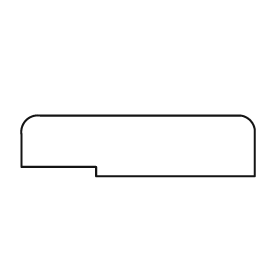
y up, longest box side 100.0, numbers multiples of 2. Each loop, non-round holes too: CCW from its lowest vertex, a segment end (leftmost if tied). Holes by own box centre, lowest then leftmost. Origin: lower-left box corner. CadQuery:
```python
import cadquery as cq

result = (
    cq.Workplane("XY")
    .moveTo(32.0, 0.0)
    .lineTo(100.0, 0.0)
    .lineTo(100.0, 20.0)
    .threePointArc((98.0, 24.0), (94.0, 26.0))
    .lineTo(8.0, 26.0)
    .threePointArc((2.0, 24.0), (0.0, 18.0))
    .lineTo(0.0, 4.0)
    .lineTo(32.0, 4.0)
    .close()
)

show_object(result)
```